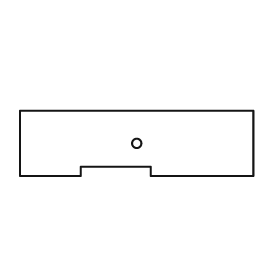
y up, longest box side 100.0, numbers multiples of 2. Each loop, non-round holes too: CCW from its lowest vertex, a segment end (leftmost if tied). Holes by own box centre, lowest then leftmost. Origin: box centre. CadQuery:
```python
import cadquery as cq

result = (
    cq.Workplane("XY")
    .moveTo(-50.0, -14.0)
    .lineTo(-24.0, -14.0)
    .lineTo(-24.0, -10.0)
    .lineTo(6.0, -10.0)
    .lineTo(6.0, -14.0)
    .lineTo(50.0, -14.0)
    .lineTo(50.0, 14.0)
    .lineTo(-50.0, 14.0)
    .close()
    .moveTo(0.0, 0.0)
    .circle(2.0)
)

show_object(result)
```